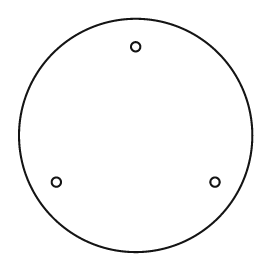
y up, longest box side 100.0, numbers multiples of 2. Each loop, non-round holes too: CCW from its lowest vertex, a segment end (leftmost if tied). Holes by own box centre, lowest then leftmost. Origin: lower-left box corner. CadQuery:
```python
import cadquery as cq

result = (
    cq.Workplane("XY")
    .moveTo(50.0, 50.0)
    .circle(50.0)
    .moveTo(16.0, 30.0)
    .circle(2.0)
    .moveTo(84.0, 30.0)
    .circle(2.0)
    .moveTo(50.0, 88.0)
    .circle(2.0)
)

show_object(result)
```